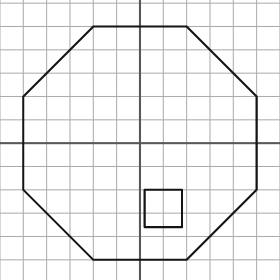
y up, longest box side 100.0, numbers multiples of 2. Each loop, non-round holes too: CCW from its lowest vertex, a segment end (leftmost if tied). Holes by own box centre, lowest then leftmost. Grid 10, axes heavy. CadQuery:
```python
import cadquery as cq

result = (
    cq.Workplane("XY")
    .moveTo(-20.0, -50.0)
    .lineTo(20.0, -50.0)
    .lineTo(50.0, -20.0)
    .lineTo(50.0, 20.0)
    .lineTo(20.0, 50.0)
    .lineTo(-20.0, 50.0)
    .lineTo(-50.0, 20.0)
    .lineTo(-50.0, -20.0)
    .close()
    .moveTo(2.0, -36.0)
    .lineTo(18.0, -36.0)
    .lineTo(18.0, -20.0)
    .lineTo(2.0, -20.0)
    .close()
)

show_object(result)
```